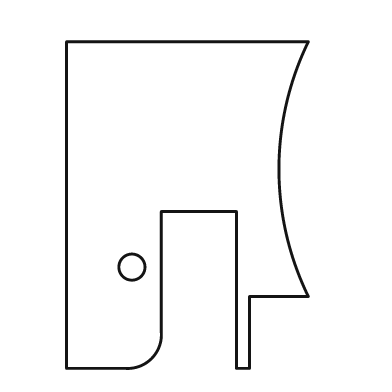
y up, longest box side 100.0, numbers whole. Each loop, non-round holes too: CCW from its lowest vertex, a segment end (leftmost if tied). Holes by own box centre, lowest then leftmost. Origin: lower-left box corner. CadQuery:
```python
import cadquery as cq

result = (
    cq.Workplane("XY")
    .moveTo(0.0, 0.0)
    .lineTo(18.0, 0.0)
    .threePointArc((26.0, 3.0), (29.0, 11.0))
    .lineTo(29.0, 48.0)
    .lineTo(52.0, 48.0)
    .lineTo(52.0, 0.0)
    .lineTo(56.0, 0.0)
    .lineTo(56.0, 22.0)
    .lineTo(74.0, 22.0)
    .threePointArc((65.0, 61.0), (74.0, 100.0))
    .lineTo(0.0, 100.0)
    .close()
    .moveTo(20.0, 31.0)
    .circle(4.0)
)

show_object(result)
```